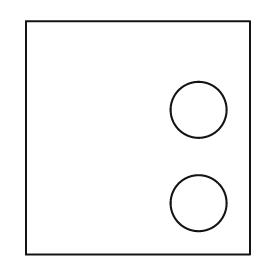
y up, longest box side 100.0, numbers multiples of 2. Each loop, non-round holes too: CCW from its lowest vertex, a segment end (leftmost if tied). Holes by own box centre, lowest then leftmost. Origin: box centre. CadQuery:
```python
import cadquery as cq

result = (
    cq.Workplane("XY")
    .moveTo(-48.0, -50.0)
    .lineTo(48.0, -50.0)
    .lineTo(48.0, 50.0)
    .lineTo(-48.0, 50.0)
    .close()
    .moveTo(26.0, -28.0)
    .circle(12.0)
    .moveTo(26.0, 12.0)
    .circle(12.0)
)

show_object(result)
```